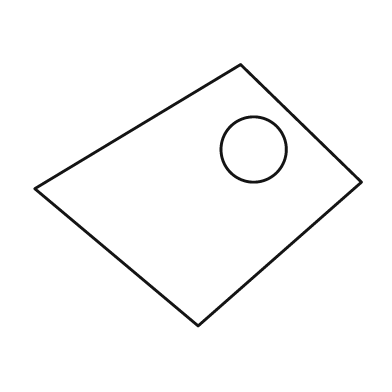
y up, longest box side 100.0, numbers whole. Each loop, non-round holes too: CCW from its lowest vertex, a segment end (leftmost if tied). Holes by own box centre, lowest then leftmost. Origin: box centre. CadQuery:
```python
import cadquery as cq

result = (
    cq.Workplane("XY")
    .moveTo(0.0, -40.0)
    .lineTo(50.0, 4.0)
    .lineTo(13.0, 40.0)
    .lineTo(-50.0, 2.0)
    .close()
    .moveTo(17.0, 14.0)
    .circle(10.0)
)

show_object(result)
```